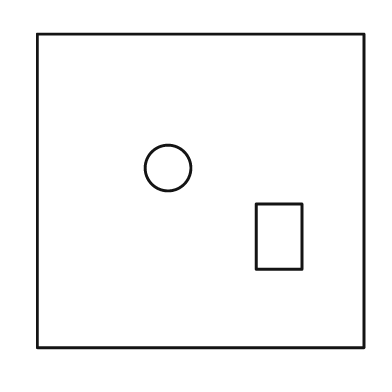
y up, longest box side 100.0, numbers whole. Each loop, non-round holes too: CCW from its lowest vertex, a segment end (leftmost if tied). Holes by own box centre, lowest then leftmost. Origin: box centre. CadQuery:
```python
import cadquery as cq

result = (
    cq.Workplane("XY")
    .moveTo(-50.0, -48.0)
    .lineTo(50.0, -48.0)
    .lineTo(50.0, 48.0)
    .lineTo(-50.0, 48.0)
    .close()
    .moveTo(17.0, -24.0)
    .lineTo(31.0, -24.0)
    .lineTo(31.0, -4.0)
    .lineTo(17.0, -4.0)
    .close()
    .moveTo(-10.0, 7.0)
    .circle(7.0)
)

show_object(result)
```